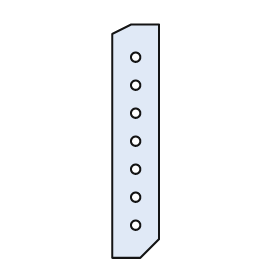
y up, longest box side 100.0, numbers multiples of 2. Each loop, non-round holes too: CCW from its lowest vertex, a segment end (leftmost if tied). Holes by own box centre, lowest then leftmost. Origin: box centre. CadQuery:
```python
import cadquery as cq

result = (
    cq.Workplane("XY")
    .moveTo(-10.0, -50.0)
    .lineTo(2.0, -50.0)
    .lineTo(10.0, -42.0)
    .lineTo(10.0, 50.0)
    .lineTo(-2.0, 50.0)
    .lineTo(-10.0, 46.0)
    .close()
    .moveTo(0.0, -36.0)
    .circle(2.0)
    .moveTo(0.0, -24.0)
    .circle(2.0)
    .moveTo(0.0, -12.0)
    .circle(2.0)
    .moveTo(0.0, 0.0)
    .circle(2.0)
    .moveTo(0.0, 12.0)
    .circle(2.0)
    .moveTo(0.0, 24.0)
    .circle(2.0)
    .moveTo(0.0, 36.0)
    .circle(2.0)
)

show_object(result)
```